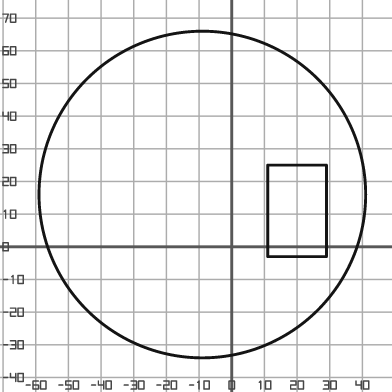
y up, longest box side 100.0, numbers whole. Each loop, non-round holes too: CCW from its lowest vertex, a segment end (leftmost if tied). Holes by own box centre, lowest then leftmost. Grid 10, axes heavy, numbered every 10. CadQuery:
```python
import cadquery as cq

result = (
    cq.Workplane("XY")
    .moveTo(-9.0, 16.0)
    .circle(50.0)
    .moveTo(11.0, -3.0)
    .lineTo(29.0, -3.0)
    .lineTo(29.0, 25.0)
    .lineTo(11.0, 25.0)
    .close()
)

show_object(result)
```